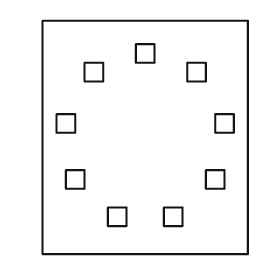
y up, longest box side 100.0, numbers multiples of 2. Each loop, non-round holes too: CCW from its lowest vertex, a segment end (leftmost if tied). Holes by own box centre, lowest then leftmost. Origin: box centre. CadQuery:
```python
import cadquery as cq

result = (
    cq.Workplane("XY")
    .moveTo(-44.0, -50.0)
    .lineTo(44.0, -50.0)
    .lineTo(44.0, 50.0)
    .lineTo(-44.0, 50.0)
    .close()
    .moveTo(-16.0, -38.0)
    .lineTo(-8.0, -38.0)
    .lineTo(-8.0, -30.0)
    .lineTo(-16.0, -30.0)
    .close()
    .moveTo(8.0, -38.0)
    .lineTo(16.0, -38.0)
    .lineTo(16.0, -30.0)
    .lineTo(8.0, -30.0)
    .close()
    .moveTo(-34.0, -22.0)
    .lineTo(-26.0, -22.0)
    .lineTo(-26.0, -14.0)
    .lineTo(-34.0, -14.0)
    .close()
    .moveTo(26.0, -22.0)
    .lineTo(34.0, -22.0)
    .lineTo(34.0, -14.0)
    .lineTo(26.0, -14.0)
    .close()
    .moveTo(-38.0, 2.0)
    .lineTo(-30.0, 2.0)
    .lineTo(-30.0, 10.0)
    .lineTo(-38.0, 10.0)
    .close()
    .moveTo(30.0, 2.0)
    .lineTo(38.0, 2.0)
    .lineTo(38.0, 10.0)
    .lineTo(30.0, 10.0)
    .close()
    .moveTo(-26.0, 24.0)
    .lineTo(-18.0, 24.0)
    .lineTo(-18.0, 32.0)
    .lineTo(-26.0, 32.0)
    .close()
    .moveTo(18.0, 24.0)
    .lineTo(26.0, 24.0)
    .lineTo(26.0, 32.0)
    .lineTo(18.0, 32.0)
    .close()
    .moveTo(-4.0, 32.0)
    .lineTo(4.0, 32.0)
    .lineTo(4.0, 40.0)
    .lineTo(-4.0, 40.0)
    .close()
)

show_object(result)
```